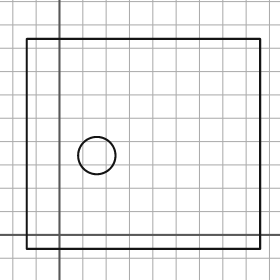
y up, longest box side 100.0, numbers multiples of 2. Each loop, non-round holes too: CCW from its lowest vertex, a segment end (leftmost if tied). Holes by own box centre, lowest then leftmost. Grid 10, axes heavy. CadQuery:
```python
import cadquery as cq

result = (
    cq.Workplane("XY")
    .moveTo(-14.0, -6.0)
    .lineTo(86.0, -6.0)
    .lineTo(86.0, 84.0)
    .lineTo(-14.0, 84.0)
    .close()
    .moveTo(16.0, 34.0)
    .circle(8.0)
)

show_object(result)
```